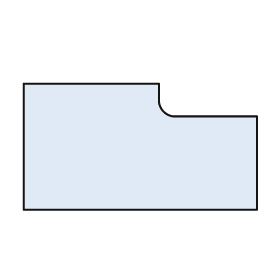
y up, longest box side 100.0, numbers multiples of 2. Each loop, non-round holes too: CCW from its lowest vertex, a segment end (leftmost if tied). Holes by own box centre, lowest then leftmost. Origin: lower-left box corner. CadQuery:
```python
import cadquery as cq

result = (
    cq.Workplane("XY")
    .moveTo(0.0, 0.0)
    .lineTo(100.0, 0.0)
    .lineTo(100.0, 40.0)
    .lineTo(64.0, 40.0)
    .threePointArc((60.0, 42.0), (58.0, 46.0))
    .lineTo(58.0, 54.0)
    .lineTo(0.0, 54.0)
    .close()
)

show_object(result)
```